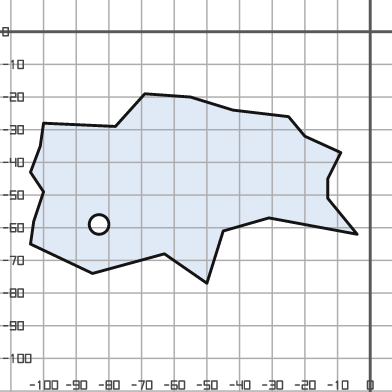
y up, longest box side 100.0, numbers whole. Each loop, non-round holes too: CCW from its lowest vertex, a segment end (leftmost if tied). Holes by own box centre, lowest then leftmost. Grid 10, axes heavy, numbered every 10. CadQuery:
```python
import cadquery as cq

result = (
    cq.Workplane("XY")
    .moveTo(-50.0, -77.0)
    .lineTo(-45.0, -61.0)
    .lineTo(-31.0, -57.0)
    .lineTo(-4.0, -62.0)
    .lineTo(-13.0, -51.0)
    .lineTo(-13.0, -45.0)
    .lineTo(-9.0, -37.0)
    .lineTo(-20.0, -32.0)
    .lineTo(-25.0, -26.0)
    .lineTo(-42.0, -24.0)
    .lineTo(-55.0, -20.0)
    .lineTo(-69.0, -19.0)
    .lineTo(-78.0, -29.0)
    .lineTo(-100.0, -28.0)
    .lineTo(-101.0, -35.0)
    .lineTo(-104.0, -43.0)
    .lineTo(-100.0, -49.0)
    .lineTo(-103.0, -58.0)
    .lineTo(-104.0, -65.0)
    .lineTo(-85.0, -74.0)
    .lineTo(-63.0, -68.0)
    .close()
    .moveTo(-83.0, -59.0)
    .circle(3.0)
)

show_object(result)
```